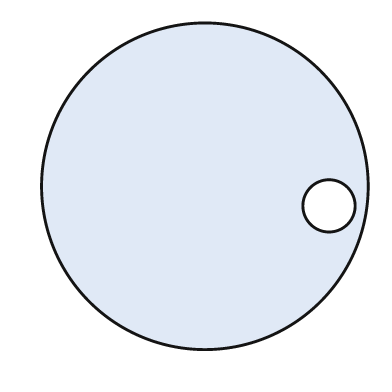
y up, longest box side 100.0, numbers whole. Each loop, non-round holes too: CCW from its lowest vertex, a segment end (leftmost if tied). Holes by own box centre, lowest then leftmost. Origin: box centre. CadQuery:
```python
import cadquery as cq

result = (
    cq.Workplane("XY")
    .moveTo(0.0, 0.0)
    .circle(50.0)
    .moveTo(38.0, -6.0)
    .circle(8.0)
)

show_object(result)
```